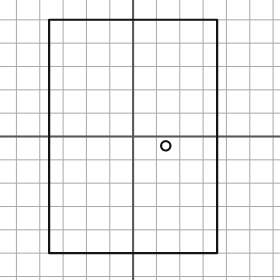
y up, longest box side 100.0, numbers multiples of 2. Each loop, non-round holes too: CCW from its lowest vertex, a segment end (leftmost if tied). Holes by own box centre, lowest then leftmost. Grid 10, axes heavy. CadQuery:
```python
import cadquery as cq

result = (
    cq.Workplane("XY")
    .moveTo(-36.0, -50.0)
    .lineTo(36.0, -50.0)
    .lineTo(36.0, 50.0)
    .lineTo(-36.0, 50.0)
    .close()
    .moveTo(14.0, -4.0)
    .circle(2.0)
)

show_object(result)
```